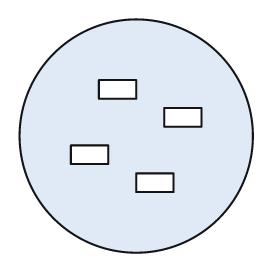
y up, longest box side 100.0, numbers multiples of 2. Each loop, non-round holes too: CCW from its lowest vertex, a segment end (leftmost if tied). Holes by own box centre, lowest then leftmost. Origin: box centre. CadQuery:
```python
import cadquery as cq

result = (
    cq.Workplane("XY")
    .moveTo(0.0, 0.0)
    .circle(50.0)
    .moveTo(0.0, -24.0)
    .lineTo(16.0, -24.0)
    .lineTo(16.0, -16.0)
    .lineTo(0.0, -16.0)
    .close()
    .moveTo(-28.0, -12.0)
    .lineTo(-12.0, -12.0)
    .lineTo(-12.0, -4.0)
    .lineTo(-28.0, -4.0)
    .close()
    .moveTo(12.0, 4.0)
    .lineTo(28.0, 4.0)
    .lineTo(28.0, 12.0)
    .lineTo(12.0, 12.0)
    .close()
    .moveTo(-16.0, 16.0)
    .lineTo(0.0, 16.0)
    .lineTo(0.0, 24.0)
    .lineTo(-16.0, 24.0)
    .close()
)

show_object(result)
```